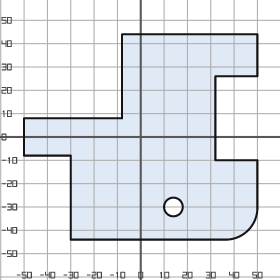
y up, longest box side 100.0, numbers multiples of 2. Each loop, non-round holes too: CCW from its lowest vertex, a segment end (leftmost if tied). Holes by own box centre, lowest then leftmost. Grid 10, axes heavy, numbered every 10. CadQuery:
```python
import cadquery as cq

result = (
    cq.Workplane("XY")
    .moveTo(-30.0, -44.0)
    .lineTo(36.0, -44.0)
    .threePointArc((46.0, -40.0), (50.0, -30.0))
    .lineTo(50.0, -10.0)
    .lineTo(32.0, -10.0)
    .lineTo(32.0, 26.0)
    .lineTo(50.0, 26.0)
    .lineTo(50.0, 44.0)
    .lineTo(-8.0, 44.0)
    .lineTo(-8.0, 8.0)
    .lineTo(-50.0, 8.0)
    .lineTo(-50.0, -8.0)
    .lineTo(-30.0, -8.0)
    .close()
    .moveTo(14.0, -30.0)
    .circle(4.0)
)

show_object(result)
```